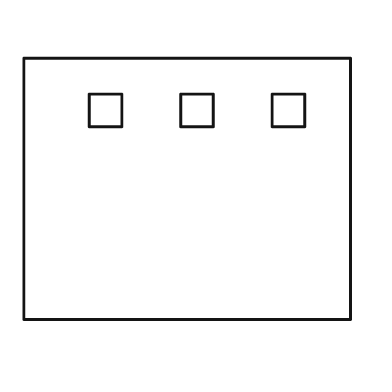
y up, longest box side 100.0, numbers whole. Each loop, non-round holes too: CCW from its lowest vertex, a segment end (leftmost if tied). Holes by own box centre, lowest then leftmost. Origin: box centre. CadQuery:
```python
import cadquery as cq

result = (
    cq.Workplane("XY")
    .moveTo(-50.0, -40.0)
    .lineTo(50.0, -40.0)
    .lineTo(50.0, 40.0)
    .lineTo(-50.0, 40.0)
    .close()
    .moveTo(-30.0, 19.0)
    .lineTo(-20.0, 19.0)
    .lineTo(-20.0, 29.0)
    .lineTo(-30.0, 29.0)
    .close()
    .moveTo(-2.0, 19.0)
    .lineTo(8.0, 19.0)
    .lineTo(8.0, 29.0)
    .lineTo(-2.0, 29.0)
    .close()
    .moveTo(26.0, 19.0)
    .lineTo(36.0, 19.0)
    .lineTo(36.0, 29.0)
    .lineTo(26.0, 29.0)
    .close()
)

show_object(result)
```